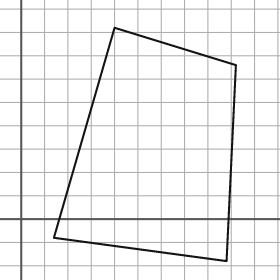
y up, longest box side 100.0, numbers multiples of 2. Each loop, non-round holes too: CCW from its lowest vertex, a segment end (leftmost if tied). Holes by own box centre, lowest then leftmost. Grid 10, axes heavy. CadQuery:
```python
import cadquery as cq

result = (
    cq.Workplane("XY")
    .moveTo(88.0, -18.0)
    .lineTo(92.0, 66.0)
    .lineTo(40.0, 82.0)
    .lineTo(14.0, -8.0)
    .close()
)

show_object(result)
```